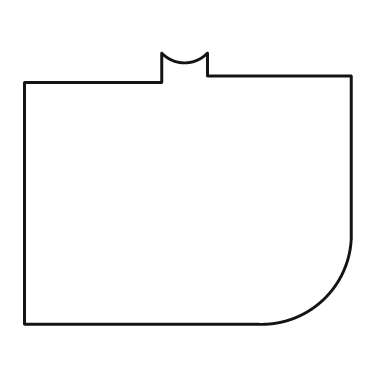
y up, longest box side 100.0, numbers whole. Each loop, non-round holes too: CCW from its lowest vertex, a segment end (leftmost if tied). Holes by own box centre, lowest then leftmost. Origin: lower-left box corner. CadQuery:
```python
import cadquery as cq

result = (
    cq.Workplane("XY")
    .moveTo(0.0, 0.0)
    .lineTo(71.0, 0.0)
    .threePointArc((92.0, 8.0), (100.0, 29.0))
    .lineTo(100.0, 76.0)
    .lineTo(56.0, 76.0)
    .lineTo(56.0, 83.0)
    .threePointArc((49.0, 80.0), (42.0, 83.0))
    .lineTo(42.0, 74.0)
    .lineTo(0.0, 74.0)
    .close()
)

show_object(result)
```